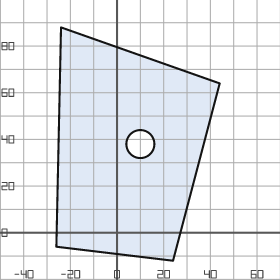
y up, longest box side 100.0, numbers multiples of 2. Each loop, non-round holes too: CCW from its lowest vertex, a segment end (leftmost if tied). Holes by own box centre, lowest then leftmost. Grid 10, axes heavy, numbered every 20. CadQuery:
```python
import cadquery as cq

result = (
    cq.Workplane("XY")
    .moveTo(24.0, -12.0)
    .lineTo(44.0, 64.0)
    .lineTo(-24.0, 88.0)
    .lineTo(-26.0, -6.0)
    .close()
    .moveTo(10.0, 38.0)
    .circle(6.0)
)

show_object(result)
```